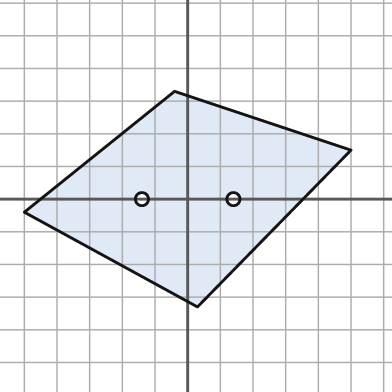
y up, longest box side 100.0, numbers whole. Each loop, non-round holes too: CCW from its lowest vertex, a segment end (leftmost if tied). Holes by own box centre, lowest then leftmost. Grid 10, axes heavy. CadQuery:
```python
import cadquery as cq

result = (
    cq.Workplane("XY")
    .moveTo(3.0, -33.0)
    .lineTo(50.0, 15.0)
    .lineTo(-4.0, 33.0)
    .lineTo(-50.0, -4.0)
    .close()
    .moveTo(-14.0, 0.0)
    .circle(2.0)
    .moveTo(14.0, 0.0)
    .circle(2.0)
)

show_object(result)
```